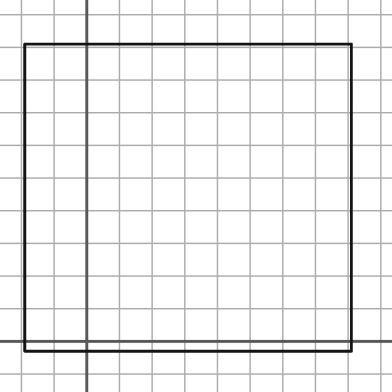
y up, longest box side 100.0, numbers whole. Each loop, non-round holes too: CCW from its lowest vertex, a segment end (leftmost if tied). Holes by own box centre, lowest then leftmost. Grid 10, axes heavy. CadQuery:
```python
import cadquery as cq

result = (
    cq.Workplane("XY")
    .moveTo(-19.0, -3.0)
    .lineTo(81.0, -3.0)
    .lineTo(81.0, 91.0)
    .lineTo(-19.0, 91.0)
    .close()
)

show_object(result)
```